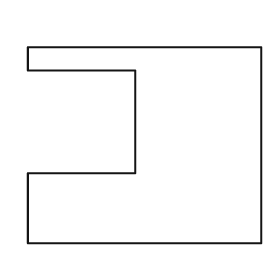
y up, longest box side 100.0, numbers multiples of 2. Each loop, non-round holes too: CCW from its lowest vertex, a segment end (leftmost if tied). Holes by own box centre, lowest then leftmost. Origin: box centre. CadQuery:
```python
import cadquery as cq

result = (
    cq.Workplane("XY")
    .moveTo(-50.0, -42.0)
    .lineTo(50.0, -42.0)
    .lineTo(50.0, 42.0)
    .lineTo(-50.0, 42.0)
    .lineTo(-50.0, 32.0)
    .lineTo(-4.0, 32.0)
    .lineTo(-4.0, -12.0)
    .lineTo(-50.0, -12.0)
    .close()
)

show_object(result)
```